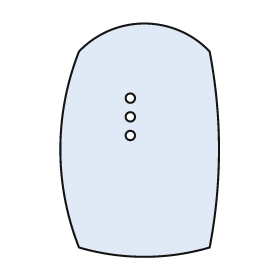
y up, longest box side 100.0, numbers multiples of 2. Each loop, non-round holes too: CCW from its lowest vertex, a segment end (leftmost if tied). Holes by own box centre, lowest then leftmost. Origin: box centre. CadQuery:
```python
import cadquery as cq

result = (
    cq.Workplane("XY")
    .moveTo(-26.0, -46.0)
    .threePointArc((2.0, -50.0), (30.0, -46.0))
    .threePointArc((34.0, -4.0), (30.0, 38.0))
    .threePointArc((2.0, 50.0), (-26.0, 38.0))
    .threePointArc((-34.0, -4.0), (-26.0, -46.0))
    .close()
    .moveTo(-4.0, 2.0)
    .circle(2.0)
    .moveTo(-4.0, 10.0)
    .circle(2.0)
    .moveTo(-4.0, 18.0)
    .circle(2.0)
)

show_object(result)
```